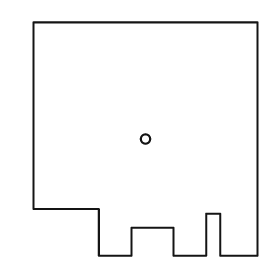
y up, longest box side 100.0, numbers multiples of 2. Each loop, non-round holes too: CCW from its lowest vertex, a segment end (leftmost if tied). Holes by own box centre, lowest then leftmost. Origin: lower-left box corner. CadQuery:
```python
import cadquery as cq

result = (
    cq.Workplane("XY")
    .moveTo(28.0, 0.0)
    .lineTo(42.0, 0.0)
    .lineTo(42.0, 12.0)
    .lineTo(60.0, 12.0)
    .lineTo(60.0, 0.0)
    .lineTo(74.0, 0.0)
    .lineTo(74.0, 18.0)
    .lineTo(80.0, 18.0)
    .lineTo(80.0, 0.0)
    .lineTo(96.0, 0.0)
    .lineTo(96.0, 100.0)
    .lineTo(0.0, 100.0)
    .lineTo(0.0, 20.0)
    .lineTo(28.0, 20.0)
    .close()
    .moveTo(48.0, 50.0)
    .circle(2.0)
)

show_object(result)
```